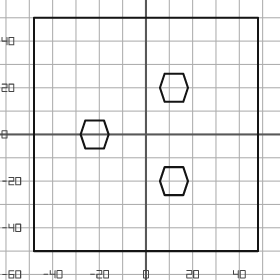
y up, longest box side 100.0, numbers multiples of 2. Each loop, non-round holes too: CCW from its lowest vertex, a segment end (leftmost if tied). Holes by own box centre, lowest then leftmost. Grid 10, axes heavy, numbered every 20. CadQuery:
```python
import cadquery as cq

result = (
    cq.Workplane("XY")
    .moveTo(-48.0, -50.0)
    .lineTo(48.0, -50.0)
    .lineTo(48.0, 50.0)
    .lineTo(-48.0, 50.0)
    .close()
    .moveTo(8.0, -26.0)
    .lineTo(16.0, -26.0)
    .lineTo(18.0, -20.0)
    .lineTo(16.0, -14.0)
    .lineTo(8.0, -14.0)
    .lineTo(6.0, -20.0)
    .close()
    .moveTo(-26.0, -6.0)
    .lineTo(-18.0, -6.0)
    .lineTo(-16.0, 0.0)
    .lineTo(-18.0, 6.0)
    .lineTo(-26.0, 6.0)
    .lineTo(-28.0, 0.0)
    .close()
    .moveTo(8.0, 14.0)
    .lineTo(16.0, 14.0)
    .lineTo(18.0, 20.0)
    .lineTo(16.0, 26.0)
    .lineTo(8.0, 26.0)
    .lineTo(6.0, 20.0)
    .close()
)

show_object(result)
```